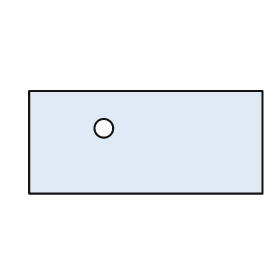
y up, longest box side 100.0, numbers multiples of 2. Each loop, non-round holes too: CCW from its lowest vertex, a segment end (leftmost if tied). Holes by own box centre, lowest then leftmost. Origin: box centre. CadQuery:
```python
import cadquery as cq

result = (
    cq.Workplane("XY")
    .moveTo(-50.0, -22.0)
    .lineTo(50.0, -22.0)
    .lineTo(50.0, 22.0)
    .lineTo(-50.0, 22.0)
    .close()
    .moveTo(-18.0, 6.0)
    .circle(4.0)
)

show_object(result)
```